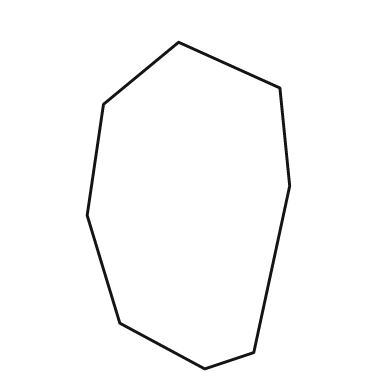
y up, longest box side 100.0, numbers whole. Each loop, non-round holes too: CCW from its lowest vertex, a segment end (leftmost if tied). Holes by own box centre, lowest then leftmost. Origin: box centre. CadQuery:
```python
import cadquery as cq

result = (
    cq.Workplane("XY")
    .moveTo(5.0, -50.0)
    .lineTo(20.0, -45.0)
    .lineTo(31.0, 6.0)
    .lineTo(28.0, 36.0)
    .lineTo(-3.0, 50.0)
    .lineTo(-26.0, 31.0)
    .lineTo(-31.0, -3.0)
    .lineTo(-21.0, -36.0)
    .close()
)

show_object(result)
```